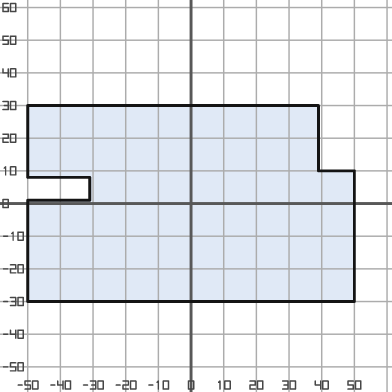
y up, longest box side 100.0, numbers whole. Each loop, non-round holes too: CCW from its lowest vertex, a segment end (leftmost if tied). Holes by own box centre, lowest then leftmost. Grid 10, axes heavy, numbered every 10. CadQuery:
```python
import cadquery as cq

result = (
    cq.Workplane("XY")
    .moveTo(-50.0, -30.0)
    .lineTo(50.0, -30.0)
    .lineTo(50.0, 10.0)
    .lineTo(39.0, 10.0)
    .lineTo(39.0, 30.0)
    .lineTo(-50.0, 30.0)
    .lineTo(-50.0, 8.0)
    .lineTo(-31.0, 8.0)
    .lineTo(-31.0, 1.0)
    .lineTo(-50.0, 1.0)
    .close()
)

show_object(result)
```